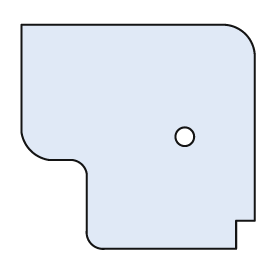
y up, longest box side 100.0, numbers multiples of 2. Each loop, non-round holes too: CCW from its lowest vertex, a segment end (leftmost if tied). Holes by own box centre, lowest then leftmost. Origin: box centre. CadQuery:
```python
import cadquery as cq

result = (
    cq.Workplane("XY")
    .moveTo(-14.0, -48.0)
    .lineTo(42.0, -48.0)
    .lineTo(42.0, -36.0)
    .lineTo(50.0, -36.0)
    .lineTo(50.0, 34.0)
    .threePointArc((46.0, 44.0), (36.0, 48.0))
    .lineTo(-50.0, 48.0)
    .lineTo(-50.0, 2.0)
    .threePointArc((-46.0, -6.0), (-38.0, -10.0))
    .lineTo(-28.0, -10.0)
    .threePointArc((-24.0, -12.0), (-22.0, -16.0))
    .lineTo(-22.0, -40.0)
    .threePointArc((-20.0, -46.0), (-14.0, -48.0))
    .close()
    .moveTo(20.0, 0.0)
    .circle(4.0)
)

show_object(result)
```